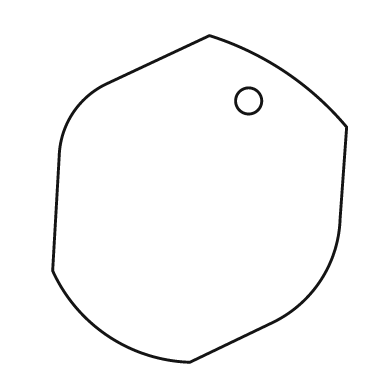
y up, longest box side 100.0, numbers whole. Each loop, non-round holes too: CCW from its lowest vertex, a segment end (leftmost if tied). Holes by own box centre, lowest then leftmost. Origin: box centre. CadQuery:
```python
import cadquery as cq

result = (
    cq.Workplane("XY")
    .moveTo(-3.0, -50.0)
    .lineTo(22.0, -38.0)
    .threePointArc((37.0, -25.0), (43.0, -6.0))
    .lineTo(45.0, 22.0)
    .threePointArc((26.0, 39.0), (3.0, 50.0))
    .lineTo(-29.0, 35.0)
    .threePointArc((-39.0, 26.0), (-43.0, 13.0))
    .lineTo(-45.0, -22.0)
    .threePointArc((-28.0, -42.0), (-3.0, -50.0))
    .close()
    .moveTo(15.0, 30.0)
    .circle(4.0)
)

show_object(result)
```